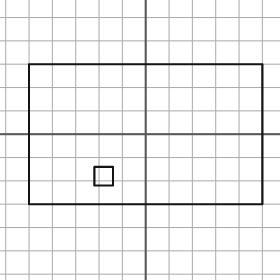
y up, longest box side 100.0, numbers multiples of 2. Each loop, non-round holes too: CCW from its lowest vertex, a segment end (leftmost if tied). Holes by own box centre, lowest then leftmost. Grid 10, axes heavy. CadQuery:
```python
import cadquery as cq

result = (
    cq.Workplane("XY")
    .moveTo(-50.0, -30.0)
    .lineTo(50.0, -30.0)
    .lineTo(50.0, 30.0)
    .lineTo(-50.0, 30.0)
    .close()
    .moveTo(-22.0, -22.0)
    .lineTo(-14.0, -22.0)
    .lineTo(-14.0, -14.0)
    .lineTo(-22.0, -14.0)
    .close()
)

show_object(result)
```